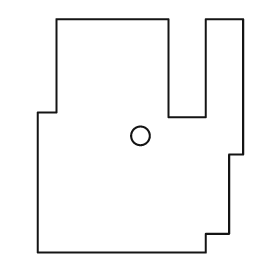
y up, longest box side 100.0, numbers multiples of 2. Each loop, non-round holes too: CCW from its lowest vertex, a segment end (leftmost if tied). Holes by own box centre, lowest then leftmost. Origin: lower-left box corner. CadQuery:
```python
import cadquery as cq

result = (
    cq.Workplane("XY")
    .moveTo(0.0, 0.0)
    .lineTo(72.0, 0.0)
    .lineTo(72.0, 8.0)
    .lineTo(82.0, 8.0)
    .lineTo(82.0, 42.0)
    .lineTo(88.0, 42.0)
    .lineTo(88.0, 100.0)
    .lineTo(72.0, 100.0)
    .lineTo(72.0, 58.0)
    .lineTo(56.0, 58.0)
    .lineTo(56.0, 100.0)
    .lineTo(8.0, 100.0)
    .lineTo(8.0, 60.0)
    .lineTo(0.0, 60.0)
    .close()
    .moveTo(44.0, 50.0)
    .circle(4.0)
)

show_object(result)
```